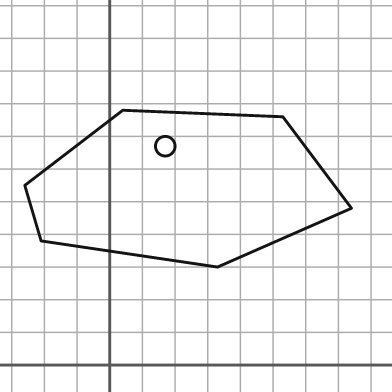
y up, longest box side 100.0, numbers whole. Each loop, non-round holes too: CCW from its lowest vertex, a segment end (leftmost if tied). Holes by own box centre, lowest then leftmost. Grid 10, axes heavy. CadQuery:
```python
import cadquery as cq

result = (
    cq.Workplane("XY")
    .moveTo(33.0, 30.0)
    .lineTo(74.0, 48.0)
    .lineTo(53.0, 76.0)
    .lineTo(4.0, 78.0)
    .lineTo(-26.0, 55.0)
    .lineTo(-21.0, 38.0)
    .close()
    .moveTo(17.0, 67.0)
    .circle(3.0)
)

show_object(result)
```